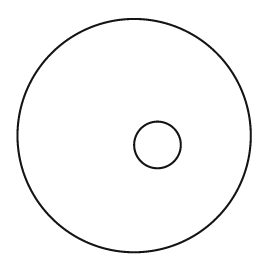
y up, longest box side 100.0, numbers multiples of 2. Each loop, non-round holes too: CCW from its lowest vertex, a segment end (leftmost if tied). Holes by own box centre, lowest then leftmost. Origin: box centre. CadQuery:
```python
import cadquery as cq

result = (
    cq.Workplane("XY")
    .moveTo(0.0, 0.0)
    .circle(50.0)
    .moveTo(10.0, -4.0)
    .circle(10.0)
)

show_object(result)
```